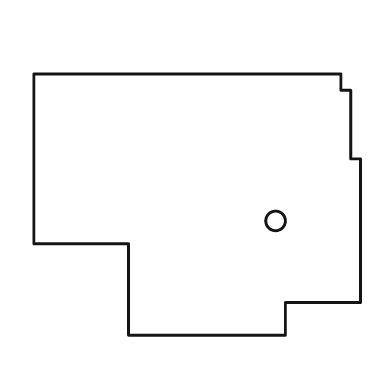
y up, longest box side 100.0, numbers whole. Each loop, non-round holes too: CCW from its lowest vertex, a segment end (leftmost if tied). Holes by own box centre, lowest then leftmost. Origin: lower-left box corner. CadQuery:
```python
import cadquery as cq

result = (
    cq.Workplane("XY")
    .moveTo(29.0, 0.0)
    .lineTo(77.0, 0.0)
    .lineTo(77.0, 10.0)
    .lineTo(100.0, 10.0)
    .lineTo(100.0, 54.0)
    .lineTo(97.0, 54.0)
    .lineTo(97.0, 75.0)
    .lineTo(94.0, 75.0)
    .lineTo(94.0, 80.0)
    .lineTo(0.0, 80.0)
    .lineTo(0.0, 28.0)
    .lineTo(29.0, 28.0)
    .close()
    .moveTo(74.0, 35.0)
    .circle(3.0)
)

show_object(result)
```